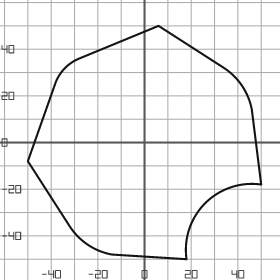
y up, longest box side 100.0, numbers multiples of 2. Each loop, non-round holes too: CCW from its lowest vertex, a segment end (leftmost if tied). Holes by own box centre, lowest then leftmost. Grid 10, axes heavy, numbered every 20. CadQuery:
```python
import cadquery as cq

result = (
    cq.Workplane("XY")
    .moveTo(18.0, -50.0)
    .threePointArc((26.0, -26.0), (50.0, -18.0))
    .lineTo(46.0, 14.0)
    .threePointArc((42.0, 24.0), (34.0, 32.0))
    .lineTo(6.0, 50.0)
    .lineTo(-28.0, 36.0)
    .threePointArc((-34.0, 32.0), (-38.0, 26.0))
    .lineTo(-50.0, -8.0)
    .lineTo(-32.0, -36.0)
    .threePointArc((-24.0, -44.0), (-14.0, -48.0))
    .close()
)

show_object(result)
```